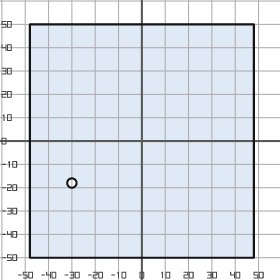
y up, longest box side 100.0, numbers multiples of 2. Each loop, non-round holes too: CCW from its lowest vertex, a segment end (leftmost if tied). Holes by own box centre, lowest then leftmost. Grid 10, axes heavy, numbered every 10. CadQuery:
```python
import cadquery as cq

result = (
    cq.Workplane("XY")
    .moveTo(-48.0, -50.0)
    .lineTo(48.0, -50.0)
    .lineTo(48.0, 50.0)
    .lineTo(-48.0, 50.0)
    .close()
    .moveTo(-30.0, -18.0)
    .circle(2.0)
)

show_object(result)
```